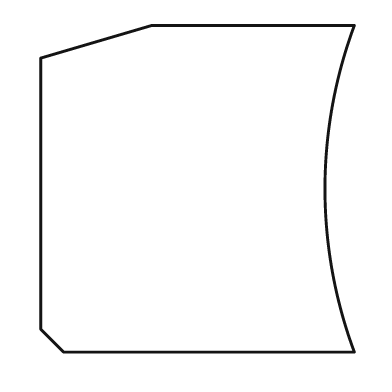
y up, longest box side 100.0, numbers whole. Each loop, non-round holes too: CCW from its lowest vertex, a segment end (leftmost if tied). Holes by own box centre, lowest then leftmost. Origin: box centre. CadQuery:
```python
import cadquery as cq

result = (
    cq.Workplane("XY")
    .moveTo(-41.0, -50.0)
    .lineTo(48.0, -50.0)
    .threePointArc((39.0, 0.0), (48.0, 50.0))
    .lineTo(-14.0, 50.0)
    .lineTo(-48.0, 40.0)
    .lineTo(-48.0, -43.0)
    .close()
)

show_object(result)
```